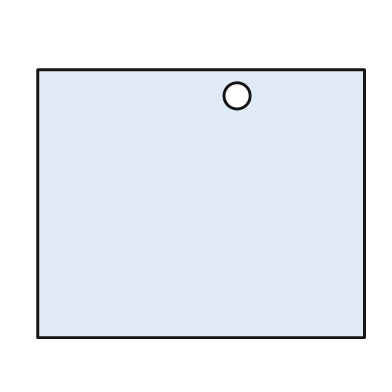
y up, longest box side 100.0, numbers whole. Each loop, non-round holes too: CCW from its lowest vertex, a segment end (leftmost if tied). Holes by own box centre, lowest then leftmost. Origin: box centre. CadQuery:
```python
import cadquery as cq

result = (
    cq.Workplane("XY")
    .moveTo(-50.0, -41.0)
    .lineTo(50.0, -41.0)
    .lineTo(50.0, 41.0)
    .lineTo(-50.0, 41.0)
    .close()
    .moveTo(11.0, 33.0)
    .circle(4.0)
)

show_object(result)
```